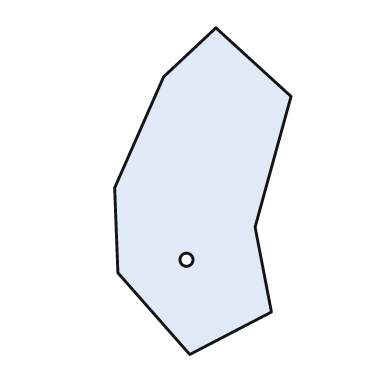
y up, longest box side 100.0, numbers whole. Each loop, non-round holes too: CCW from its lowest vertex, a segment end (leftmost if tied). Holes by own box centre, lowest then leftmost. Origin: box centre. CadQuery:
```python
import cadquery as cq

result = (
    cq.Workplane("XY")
    .moveTo(-4.0, -50.0)
    .lineTo(21.0, -37.0)
    .lineTo(16.0, -11.0)
    .lineTo(27.0, 29.0)
    .lineTo(4.0, 50.0)
    .lineTo(-12.0, 35.0)
    .lineTo(-27.0, 1.0)
    .lineTo(-26.0, -25.0)
    .close()
    .moveTo(-5.0, -21.0)
    .circle(2.0)
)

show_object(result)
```